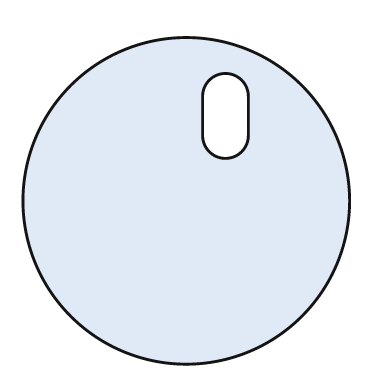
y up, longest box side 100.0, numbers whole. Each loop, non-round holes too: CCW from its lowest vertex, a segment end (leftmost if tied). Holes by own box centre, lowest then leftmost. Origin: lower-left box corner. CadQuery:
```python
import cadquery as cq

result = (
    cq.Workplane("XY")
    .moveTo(50.0, 50.0)
    .circle(50.0)
    .moveTo(55.0, 70.0)
    .threePointArc((62.0, 63.0), (69.0, 70.0))
    .lineTo(69.0, 82.0)
    .threePointArc((62.0, 89.0), (55.0, 82.0))
    .close()
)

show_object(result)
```